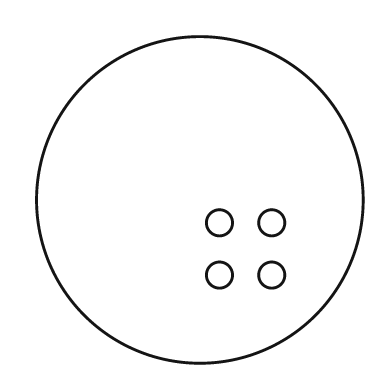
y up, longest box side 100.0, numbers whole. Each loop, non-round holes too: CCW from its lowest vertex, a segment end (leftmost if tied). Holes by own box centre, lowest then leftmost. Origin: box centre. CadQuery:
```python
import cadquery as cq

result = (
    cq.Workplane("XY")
    .moveTo(0.0, 0.0)
    .circle(50.0)
    .moveTo(6.0, -23.0)
    .circle(4.0)
    .moveTo(22.0, -23.0)
    .circle(4.0)
    .moveTo(6.0, -7.0)
    .circle(4.0)
    .moveTo(22.0, -7.0)
    .circle(4.0)
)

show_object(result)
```